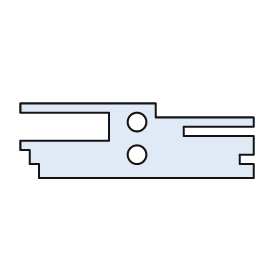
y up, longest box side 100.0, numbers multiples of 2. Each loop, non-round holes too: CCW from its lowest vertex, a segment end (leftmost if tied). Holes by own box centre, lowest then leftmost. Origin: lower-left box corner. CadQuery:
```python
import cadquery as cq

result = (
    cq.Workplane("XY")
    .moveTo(8.0, 0.0)
    .lineTo(100.0, 0.0)
    .lineTo(100.0, 6.0)
    .lineTo(94.0, 6.0)
    .lineTo(94.0, 10.0)
    .lineTo(100.0, 10.0)
    .lineTo(100.0, 18.0)
    .lineTo(70.0, 18.0)
    .lineTo(70.0, 22.0)
    .lineTo(100.0, 22.0)
    .lineTo(100.0, 26.0)
    .lineTo(58.0, 26.0)
    .lineTo(58.0, 32.0)
    .lineTo(0.0, 32.0)
    .lineTo(0.0, 28.0)
    .lineTo(38.0, 28.0)
    .lineTo(38.0, 16.0)
    .lineTo(0.0, 16.0)
    .lineTo(0.0, 12.0)
    .lineTo(4.0, 12.0)
    .lineTo(4.0, 6.0)
    .lineTo(8.0, 6.0)
    .close()
    .moveTo(50.0, 10.0)
    .circle(4.0)
    .moveTo(50.0, 24.0)
    .circle(4.0)
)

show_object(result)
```